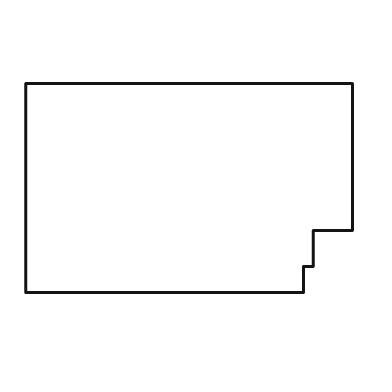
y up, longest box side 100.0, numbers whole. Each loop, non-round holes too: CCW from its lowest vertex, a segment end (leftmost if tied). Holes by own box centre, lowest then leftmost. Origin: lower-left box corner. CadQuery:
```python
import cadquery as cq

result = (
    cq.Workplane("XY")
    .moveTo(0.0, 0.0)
    .lineTo(85.0, 0.0)
    .lineTo(85.0, 8.0)
    .lineTo(88.0, 8.0)
    .lineTo(88.0, 19.0)
    .lineTo(100.0, 19.0)
    .lineTo(100.0, 64.0)
    .lineTo(0.0, 64.0)
    .close()
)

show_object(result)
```